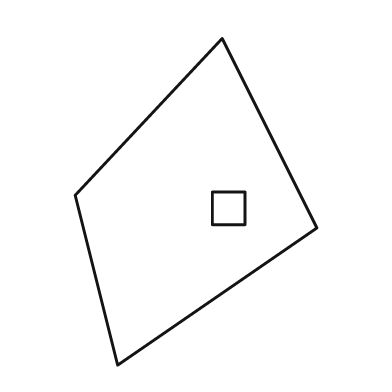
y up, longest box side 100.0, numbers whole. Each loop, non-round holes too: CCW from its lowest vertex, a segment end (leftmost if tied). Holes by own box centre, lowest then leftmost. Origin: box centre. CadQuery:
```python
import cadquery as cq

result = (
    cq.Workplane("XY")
    .moveTo(-24.0, -50.0)
    .lineTo(37.0, -8.0)
    .lineTo(8.0, 50.0)
    .lineTo(-37.0, 2.0)
    .close()
    .moveTo(5.0, -7.0)
    .lineTo(15.0, -7.0)
    .lineTo(15.0, 3.0)
    .lineTo(5.0, 3.0)
    .close()
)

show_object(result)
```